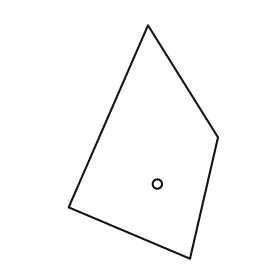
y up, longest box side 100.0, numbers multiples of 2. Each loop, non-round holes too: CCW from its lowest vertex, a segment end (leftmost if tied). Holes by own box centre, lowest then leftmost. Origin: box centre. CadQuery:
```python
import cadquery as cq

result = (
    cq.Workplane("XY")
    .moveTo(20.0, -50.0)
    .lineTo(32.0, 2.0)
    .lineTo(2.0, 50.0)
    .lineTo(-32.0, -28.0)
    .close()
    .moveTo(6.0, -18.0)
    .circle(2.0)
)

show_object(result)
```